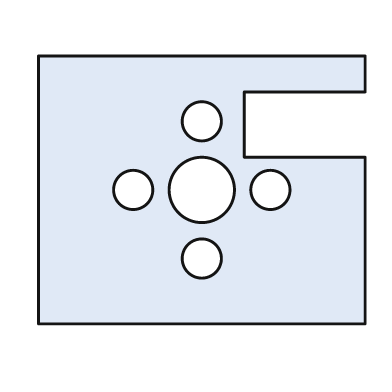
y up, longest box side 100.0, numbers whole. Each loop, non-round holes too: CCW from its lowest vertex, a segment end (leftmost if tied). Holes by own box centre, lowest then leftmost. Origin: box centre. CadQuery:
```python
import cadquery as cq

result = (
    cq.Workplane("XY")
    .moveTo(-50.0, -41.0)
    .lineTo(50.0, -41.0)
    .lineTo(50.0, 10.0)
    .lineTo(13.0, 10.0)
    .lineTo(13.0, 30.0)
    .lineTo(50.0, 30.0)
    .lineTo(50.0, 41.0)
    .lineTo(-50.0, 41.0)
    .close()
    .moveTo(0.0, -21.0)
    .circle(6.0)
    .moveTo(-21.0, 0.0)
    .circle(6.0)
    .moveTo(0.0, 0.0)
    .circle(10.0)
    .moveTo(21.0, 0.0)
    .circle(6.0)
    .moveTo(0.0, 21.0)
    .circle(6.0)
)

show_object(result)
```